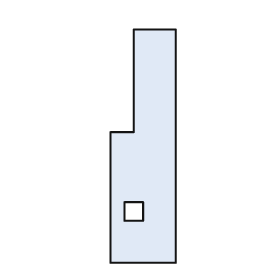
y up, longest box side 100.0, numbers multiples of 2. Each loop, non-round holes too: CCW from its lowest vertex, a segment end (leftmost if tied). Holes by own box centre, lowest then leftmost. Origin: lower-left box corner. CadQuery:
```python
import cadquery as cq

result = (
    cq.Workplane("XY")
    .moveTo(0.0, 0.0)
    .lineTo(28.0, 0.0)
    .lineTo(28.0, 100.0)
    .lineTo(10.0, 100.0)
    .lineTo(10.0, 56.0)
    .lineTo(0.0, 56.0)
    .close()
    .moveTo(6.0, 18.0)
    .lineTo(14.0, 18.0)
    .lineTo(14.0, 26.0)
    .lineTo(6.0, 26.0)
    .close()
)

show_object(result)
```